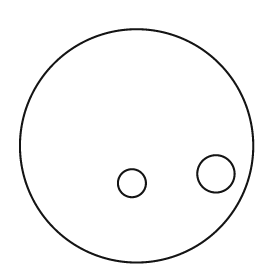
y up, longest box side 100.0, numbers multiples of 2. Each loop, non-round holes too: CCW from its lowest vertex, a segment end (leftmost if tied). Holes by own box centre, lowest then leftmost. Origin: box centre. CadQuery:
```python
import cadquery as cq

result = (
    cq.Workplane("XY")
    .moveTo(0.0, 0.0)
    .circle(50.0)
    .moveTo(-2.0, -16.0)
    .circle(6.0)
    .moveTo(34.0, -12.0)
    .circle(8.0)
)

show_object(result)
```